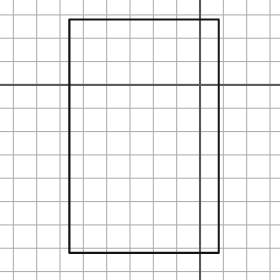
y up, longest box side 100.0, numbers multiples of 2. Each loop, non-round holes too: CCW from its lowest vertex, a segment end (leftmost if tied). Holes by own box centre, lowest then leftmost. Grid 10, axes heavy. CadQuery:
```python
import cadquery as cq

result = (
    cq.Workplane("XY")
    .moveTo(-56.0, -72.0)
    .lineTo(8.0, -72.0)
    .lineTo(8.0, 28.0)
    .lineTo(-56.0, 28.0)
    .close()
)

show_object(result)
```